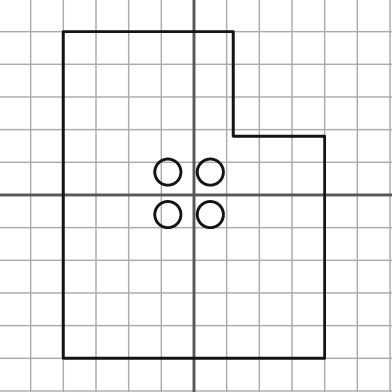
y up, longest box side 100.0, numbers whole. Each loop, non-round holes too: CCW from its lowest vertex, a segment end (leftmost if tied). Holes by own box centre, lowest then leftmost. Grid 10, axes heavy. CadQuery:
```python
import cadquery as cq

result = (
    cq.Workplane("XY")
    .moveTo(-40.0, -50.0)
    .lineTo(40.0, -50.0)
    .lineTo(40.0, 18.0)
    .lineTo(12.0, 18.0)
    .lineTo(12.0, 50.0)
    .lineTo(-40.0, 50.0)
    .close()
    .moveTo(-8.0, -6.0)
    .circle(4.0)
    .moveTo(5.0, -6.0)
    .circle(4.0)
    .moveTo(-8.0, 7.0)
    .circle(4.0)
    .moveTo(5.0, 7.0)
    .circle(4.0)
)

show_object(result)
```